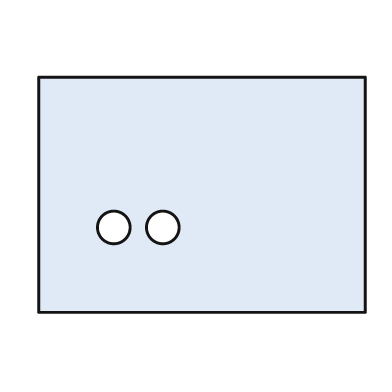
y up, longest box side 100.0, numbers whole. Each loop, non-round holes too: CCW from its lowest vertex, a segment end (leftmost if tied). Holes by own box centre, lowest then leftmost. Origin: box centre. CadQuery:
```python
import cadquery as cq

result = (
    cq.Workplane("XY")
    .moveTo(-50.0, -36.0)
    .lineTo(50.0, -36.0)
    .lineTo(50.0, 36.0)
    .lineTo(-50.0, 36.0)
    .close()
    .moveTo(-27.0, -10.0)
    .circle(5.0)
    .moveTo(-12.0, -10.0)
    .circle(5.0)
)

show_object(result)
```